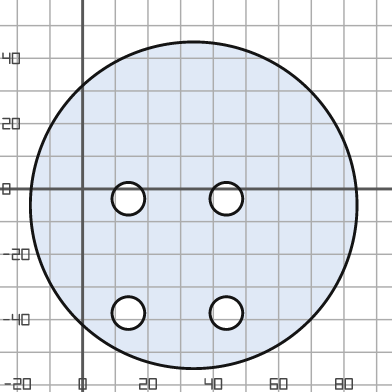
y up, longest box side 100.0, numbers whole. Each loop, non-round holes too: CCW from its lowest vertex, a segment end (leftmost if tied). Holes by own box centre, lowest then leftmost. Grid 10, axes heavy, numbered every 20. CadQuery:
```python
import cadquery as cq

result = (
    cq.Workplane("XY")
    .moveTo(34.0, -5.0)
    .circle(50.0)
    .moveTo(14.0, -38.0)
    .circle(5.0)
    .moveTo(44.0, -38.0)
    .circle(5.0)
    .moveTo(14.0, -3.0)
    .circle(5.0)
    .moveTo(44.0, -3.0)
    .circle(5.0)
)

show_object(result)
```